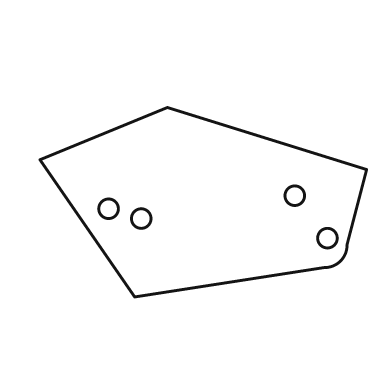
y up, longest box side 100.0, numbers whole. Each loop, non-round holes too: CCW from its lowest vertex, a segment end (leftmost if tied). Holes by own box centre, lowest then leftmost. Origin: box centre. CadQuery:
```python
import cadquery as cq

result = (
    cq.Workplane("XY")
    .moveTo(-21.0, -29.0)
    .lineTo(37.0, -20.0)
    .threePointArc((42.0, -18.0), (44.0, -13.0))
    .lineTo(50.0, 10.0)
    .lineTo(-11.0, 29.0)
    .lineTo(-50.0, 13.0)
    .close()
    .moveTo(38.0, -11.0)
    .circle(3.0)
    .moveTo(-19.0, -5.0)
    .circle(3.0)
    .moveTo(-29.0, -2.0)
    .circle(3.0)
    .moveTo(28.0, 2.0)
    .circle(3.0)
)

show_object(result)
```